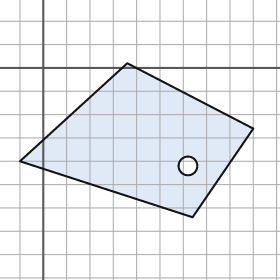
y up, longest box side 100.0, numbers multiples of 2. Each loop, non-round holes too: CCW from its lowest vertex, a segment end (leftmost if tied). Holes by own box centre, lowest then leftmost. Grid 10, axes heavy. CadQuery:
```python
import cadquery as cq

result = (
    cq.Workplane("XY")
    .moveTo(64.0, -64.0)
    .lineTo(90.0, -26.0)
    .lineTo(36.0, 2.0)
    .lineTo(-10.0, -40.0)
    .close()
    .moveTo(62.0, -42.0)
    .circle(4.0)
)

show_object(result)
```